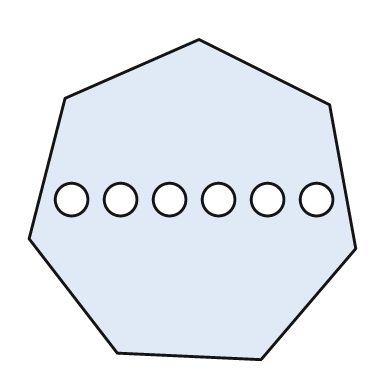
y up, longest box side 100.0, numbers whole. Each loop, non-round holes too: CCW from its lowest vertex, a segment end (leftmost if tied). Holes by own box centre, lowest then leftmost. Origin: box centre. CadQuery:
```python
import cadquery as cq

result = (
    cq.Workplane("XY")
    .moveTo(21.0, -49.0)
    .lineTo(50.0, -15.0)
    .lineTo(42.0, 29.0)
    .lineTo(2.0, 49.0)
    .lineTo(-39.0, 31.0)
    .lineTo(-50.0, -12.0)
    .lineTo(-23.0, -47.0)
    .close()
    .moveTo(-37.0, 0.0)
    .circle(5.0)
    .moveTo(-22.0, 0.0)
    .circle(5.0)
    .moveTo(-7.0, 0.0)
    .circle(5.0)
    .moveTo(8.0, 0.0)
    .circle(5.0)
    .moveTo(23.0, 0.0)
    .circle(5.0)
    .moveTo(38.0, 0.0)
    .circle(5.0)
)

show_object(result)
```